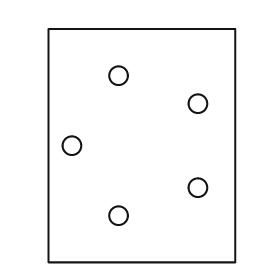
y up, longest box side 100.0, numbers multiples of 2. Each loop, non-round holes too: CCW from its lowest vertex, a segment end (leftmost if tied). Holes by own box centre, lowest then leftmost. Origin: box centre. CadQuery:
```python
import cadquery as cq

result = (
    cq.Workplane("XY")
    .moveTo(-40.0, -50.0)
    .lineTo(40.0, -50.0)
    .lineTo(40.0, 50.0)
    .lineTo(-40.0, 50.0)
    .close()
    .moveTo(-10.0, -30.0)
    .circle(4.0)
    .moveTo(24.0, -18.0)
    .circle(4.0)
    .moveTo(-30.0, 0.0)
    .circle(4.0)
    .moveTo(24.0, 18.0)
    .circle(4.0)
    .moveTo(-10.0, 30.0)
    .circle(4.0)
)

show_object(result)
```